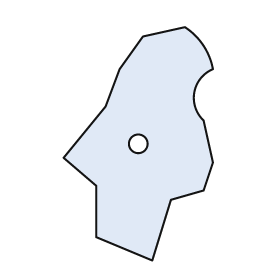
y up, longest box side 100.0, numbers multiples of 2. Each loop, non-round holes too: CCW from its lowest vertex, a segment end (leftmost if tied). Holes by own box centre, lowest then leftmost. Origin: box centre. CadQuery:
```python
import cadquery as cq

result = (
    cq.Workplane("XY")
    .moveTo(6.0, -50.0)
    .lineTo(14.0, -24.0)
    .lineTo(28.0, -20.0)
    .lineTo(32.0, -8.0)
    .lineTo(28.0, 10.0)
    .threePointArc((24.0, 22.0), (32.0, 32.0))
    .threePointArc((28.0, 42.0), (20.0, 50.0))
    .lineTo(2.0, 46.0)
    .lineTo(-8.0, 32.0)
    .lineTo(-14.0, 16.0)
    .lineTo(-32.0, -6.0)
    .lineTo(-18.0, -18.0)
    .lineTo(-18.0, -40.0)
    .close()
    .moveTo(0.0, 0.0)
    .circle(4.0)
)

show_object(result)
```